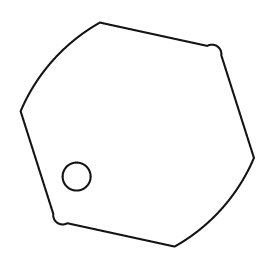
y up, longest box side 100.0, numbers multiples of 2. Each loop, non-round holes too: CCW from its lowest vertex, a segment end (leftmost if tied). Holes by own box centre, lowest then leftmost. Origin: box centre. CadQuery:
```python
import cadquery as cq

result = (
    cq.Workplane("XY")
    .moveTo(16.0, -48.0)
    .threePointArc((36.0, -32.0), (50.0, -10.0))
    .lineTo(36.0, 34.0)
    .threePointArc((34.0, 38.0), (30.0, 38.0))
    .lineTo(-16.0, 48.0)
    .threePointArc((-36.0, 32.0), (-50.0, 10.0))
    .lineTo(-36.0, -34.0)
    .threePointArc((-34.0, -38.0), (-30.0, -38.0))
    .close()
    .moveTo(-26.0, -18.0)
    .circle(6.0)
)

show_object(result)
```